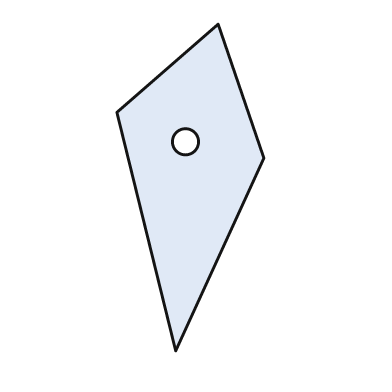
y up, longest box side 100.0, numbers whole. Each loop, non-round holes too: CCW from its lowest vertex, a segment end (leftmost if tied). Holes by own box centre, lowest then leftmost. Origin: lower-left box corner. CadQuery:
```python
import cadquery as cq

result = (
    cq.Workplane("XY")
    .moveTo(18.0, 0.0)
    .lineTo(45.0, 59.0)
    .lineTo(31.0, 100.0)
    .lineTo(0.0, 73.0)
    .close()
    .moveTo(21.0, 64.0)
    .circle(4.0)
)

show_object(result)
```